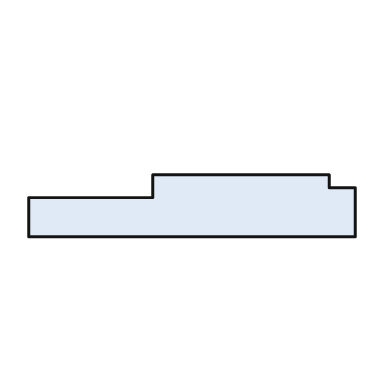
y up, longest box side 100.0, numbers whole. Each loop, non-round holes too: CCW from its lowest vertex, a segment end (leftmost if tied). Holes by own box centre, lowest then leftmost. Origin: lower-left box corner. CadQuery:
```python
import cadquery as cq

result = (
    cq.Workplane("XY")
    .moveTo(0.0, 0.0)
    .lineTo(100.0, 0.0)
    .lineTo(100.0, 15.0)
    .lineTo(92.0, 15.0)
    .lineTo(92.0, 19.0)
    .lineTo(38.0, 19.0)
    .lineTo(38.0, 12.0)
    .lineTo(0.0, 12.0)
    .close()
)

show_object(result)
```